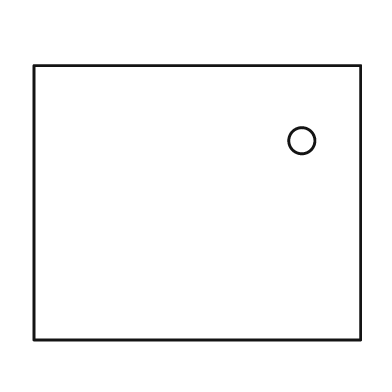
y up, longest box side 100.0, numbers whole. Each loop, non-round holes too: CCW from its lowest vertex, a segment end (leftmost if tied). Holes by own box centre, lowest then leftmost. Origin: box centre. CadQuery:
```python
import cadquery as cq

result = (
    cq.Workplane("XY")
    .moveTo(-50.0, -42.0)
    .lineTo(50.0, -42.0)
    .lineTo(50.0, 42.0)
    .lineTo(-50.0, 42.0)
    .close()
    .moveTo(32.0, 19.0)
    .circle(4.0)
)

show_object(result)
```